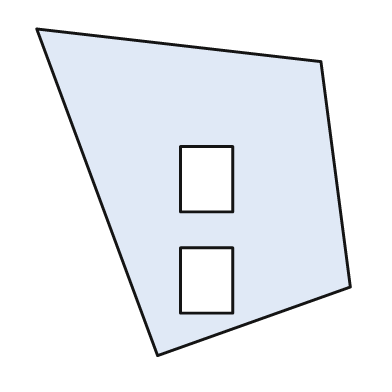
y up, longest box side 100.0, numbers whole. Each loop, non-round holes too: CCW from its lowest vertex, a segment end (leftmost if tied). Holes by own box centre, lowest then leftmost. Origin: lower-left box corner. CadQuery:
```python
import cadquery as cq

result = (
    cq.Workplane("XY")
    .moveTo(37.0, 0.0)
    .lineTo(96.0, 21.0)
    .lineTo(87.0, 90.0)
    .lineTo(0.0, 100.0)
    .close()
    .moveTo(44.0, 13.0)
    .lineTo(60.0, 13.0)
    .lineTo(60.0, 33.0)
    .lineTo(44.0, 33.0)
    .close()
    .moveTo(44.0, 44.0)
    .lineTo(60.0, 44.0)
    .lineTo(60.0, 64.0)
    .lineTo(44.0, 64.0)
    .close()
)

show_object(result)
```